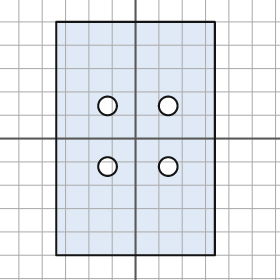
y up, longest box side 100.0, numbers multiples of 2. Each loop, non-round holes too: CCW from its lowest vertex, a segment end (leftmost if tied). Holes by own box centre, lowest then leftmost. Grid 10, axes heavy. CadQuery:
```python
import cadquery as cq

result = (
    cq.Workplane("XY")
    .moveTo(-34.0, -50.0)
    .lineTo(34.0, -50.0)
    .lineTo(34.0, 50.0)
    .lineTo(-34.0, 50.0)
    .close()
    .moveTo(-12.0, -12.0)
    .circle(4.0)
    .moveTo(14.0, -12.0)
    .circle(4.0)
    .moveTo(-12.0, 14.0)
    .circle(4.0)
    .moveTo(14.0, 14.0)
    .circle(4.0)
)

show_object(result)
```